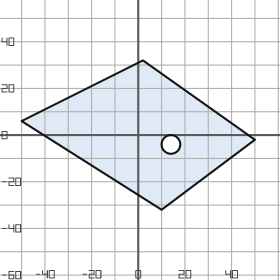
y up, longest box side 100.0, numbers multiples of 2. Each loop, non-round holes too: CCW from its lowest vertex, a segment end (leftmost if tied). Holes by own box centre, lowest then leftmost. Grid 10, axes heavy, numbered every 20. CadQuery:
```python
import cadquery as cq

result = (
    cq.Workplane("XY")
    .moveTo(10.0, -32.0)
    .lineTo(50.0, -2.0)
    .lineTo(2.0, 32.0)
    .lineTo(-50.0, 6.0)
    .close()
    .moveTo(14.0, -4.0)
    .circle(4.0)
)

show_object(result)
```